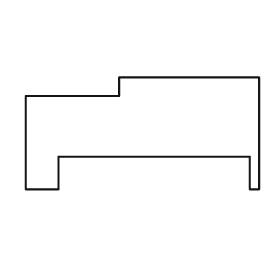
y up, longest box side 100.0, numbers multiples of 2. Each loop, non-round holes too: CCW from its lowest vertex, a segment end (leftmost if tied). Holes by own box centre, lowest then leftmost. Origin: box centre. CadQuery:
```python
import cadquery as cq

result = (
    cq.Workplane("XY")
    .moveTo(-50.0, -24.0)
    .lineTo(-36.0, -24.0)
    .lineTo(-36.0, -10.0)
    .lineTo(46.0, -10.0)
    .lineTo(46.0, -24.0)
    .lineTo(50.0, -24.0)
    .lineTo(50.0, 24.0)
    .lineTo(-10.0, 24.0)
    .lineTo(-10.0, 16.0)
    .lineTo(-50.0, 16.0)
    .close()
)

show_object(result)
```